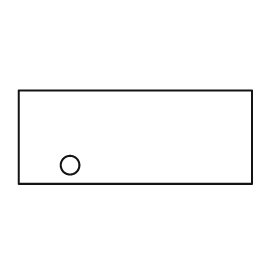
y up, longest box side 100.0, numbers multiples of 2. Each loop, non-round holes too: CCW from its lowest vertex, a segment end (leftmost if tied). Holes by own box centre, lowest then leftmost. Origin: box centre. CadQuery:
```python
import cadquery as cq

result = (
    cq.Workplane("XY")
    .moveTo(-50.0, -20.0)
    .lineTo(50.0, -20.0)
    .lineTo(50.0, 20.0)
    .lineTo(-50.0, 20.0)
    .close()
    .moveTo(-28.0, -12.0)
    .circle(4.0)
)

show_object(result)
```